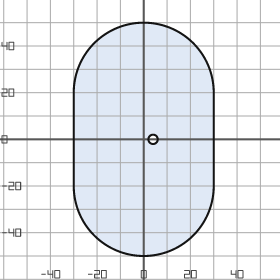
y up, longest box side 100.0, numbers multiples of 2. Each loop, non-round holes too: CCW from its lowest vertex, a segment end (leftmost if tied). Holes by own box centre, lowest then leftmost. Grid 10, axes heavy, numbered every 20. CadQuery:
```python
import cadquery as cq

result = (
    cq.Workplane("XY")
    .moveTo(-30.0, -20.0)
    .threePointArc((0.0, -50.0), (30.0, -20.0))
    .lineTo(30.0, 20.0)
    .threePointArc((0.0, 50.0), (-30.0, 20.0))
    .close()
    .moveTo(4.0, 0.0)
    .circle(2.0)
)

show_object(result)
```